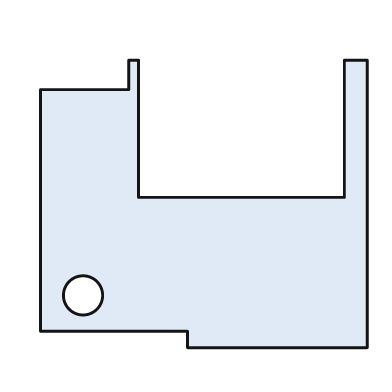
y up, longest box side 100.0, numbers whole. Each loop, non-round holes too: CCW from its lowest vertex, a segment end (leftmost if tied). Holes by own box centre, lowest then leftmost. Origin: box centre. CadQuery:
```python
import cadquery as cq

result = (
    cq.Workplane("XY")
    .moveTo(-5.0, -44.0)
    .lineTo(50.0, -44.0)
    .lineTo(50.0, 44.0)
    .lineTo(43.0, 44.0)
    .lineTo(43.0, 2.0)
    .lineTo(-20.0, 2.0)
    .lineTo(-20.0, 44.0)
    .lineTo(-23.0, 44.0)
    .lineTo(-23.0, 35.0)
    .lineTo(-50.0, 35.0)
    .lineTo(-50.0, -39.0)
    .lineTo(-5.0, -39.0)
    .close()
    .moveTo(-37.0, -28.0)
    .circle(6.0)
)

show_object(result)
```